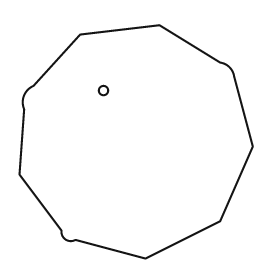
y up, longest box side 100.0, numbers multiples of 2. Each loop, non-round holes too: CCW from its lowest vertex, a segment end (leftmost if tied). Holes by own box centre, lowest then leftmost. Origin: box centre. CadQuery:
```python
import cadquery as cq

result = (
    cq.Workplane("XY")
    .moveTo(4.0, -50.0)
    .lineTo(36.0, -34.0)
    .lineTo(50.0, -2.0)
    .lineTo(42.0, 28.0)
    .threePointArc((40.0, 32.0), (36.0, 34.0))
    .lineTo(10.0, 50.0)
    .lineTo(-24.0, 46.0)
    .lineTo(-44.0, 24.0)
    .threePointArc((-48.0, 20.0), (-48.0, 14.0))
    .lineTo(-50.0, -14.0)
    .lineTo(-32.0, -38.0)
    .threePointArc((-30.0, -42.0), (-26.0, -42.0))
    .close()
    .moveTo(-14.0, 22.0)
    .circle(2.0)
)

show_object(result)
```